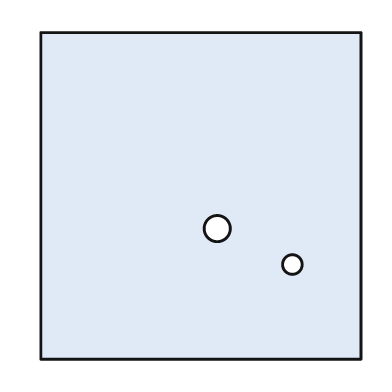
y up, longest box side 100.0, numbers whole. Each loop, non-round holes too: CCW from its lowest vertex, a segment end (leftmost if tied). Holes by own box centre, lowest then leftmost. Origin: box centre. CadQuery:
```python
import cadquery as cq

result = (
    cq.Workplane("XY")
    .moveTo(-49.0, -50.0)
    .lineTo(49.0, -50.0)
    .lineTo(49.0, 50.0)
    .lineTo(-49.0, 50.0)
    .close()
    .moveTo(28.0, -21.0)
    .circle(3.0)
    .moveTo(5.0, -10.0)
    .circle(4.0)
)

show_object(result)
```